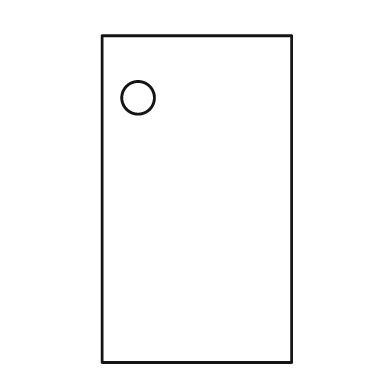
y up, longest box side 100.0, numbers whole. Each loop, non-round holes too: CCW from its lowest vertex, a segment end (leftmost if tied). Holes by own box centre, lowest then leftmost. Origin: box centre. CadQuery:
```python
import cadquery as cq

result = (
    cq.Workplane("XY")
    .moveTo(-29.0, -50.0)
    .lineTo(29.0, -50.0)
    .lineTo(29.0, 50.0)
    .lineTo(-29.0, 50.0)
    .close()
    .moveTo(-18.0, 31.0)
    .circle(5.0)
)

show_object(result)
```